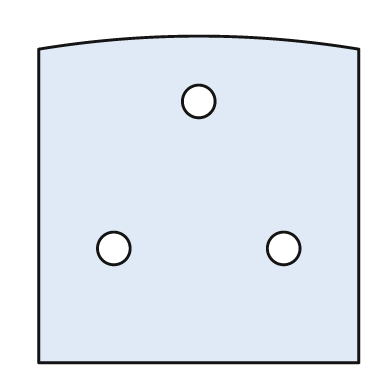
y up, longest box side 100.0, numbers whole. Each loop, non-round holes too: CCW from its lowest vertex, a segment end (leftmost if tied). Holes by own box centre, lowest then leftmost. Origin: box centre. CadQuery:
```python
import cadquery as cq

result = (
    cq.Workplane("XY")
    .moveTo(-49.0, -50.0)
    .lineTo(49.0, -50.0)
    .lineTo(49.0, 46.0)
    .threePointArc((0.0, 50.0), (-49.0, 46.0))
    .close()
    .moveTo(-26.0, -15.0)
    .circle(5.0)
    .moveTo(26.0, -15.0)
    .circle(5.0)
    .moveTo(0.0, 30.0)
    .circle(5.0)
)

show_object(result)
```